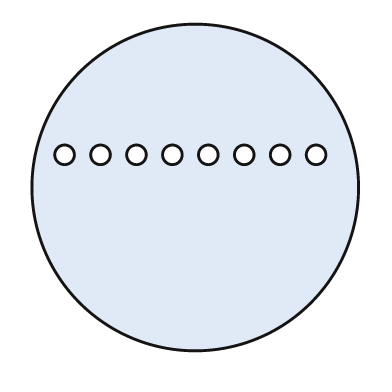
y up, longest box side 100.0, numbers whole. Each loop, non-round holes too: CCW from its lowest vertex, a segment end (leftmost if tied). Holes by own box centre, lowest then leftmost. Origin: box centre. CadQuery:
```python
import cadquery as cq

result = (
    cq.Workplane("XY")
    .moveTo(0.0, 0.0)
    .circle(50.0)
    .moveTo(-40.0, 10.0)
    .circle(3.0)
    .moveTo(-29.0, 10.0)
    .circle(3.0)
    .moveTo(-18.0, 10.0)
    .circle(3.0)
    .moveTo(-7.0, 10.0)
    .circle(3.0)
    .moveTo(4.0, 10.0)
    .circle(3.0)
    .moveTo(15.0, 10.0)
    .circle(3.0)
    .moveTo(26.0, 10.0)
    .circle(3.0)
    .moveTo(37.0, 10.0)
    .circle(3.0)
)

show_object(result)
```